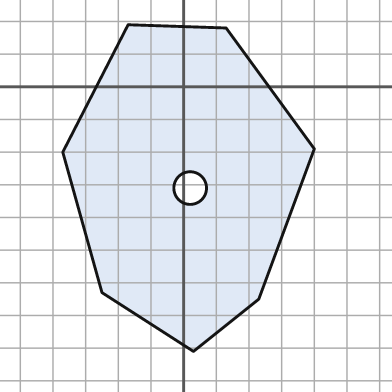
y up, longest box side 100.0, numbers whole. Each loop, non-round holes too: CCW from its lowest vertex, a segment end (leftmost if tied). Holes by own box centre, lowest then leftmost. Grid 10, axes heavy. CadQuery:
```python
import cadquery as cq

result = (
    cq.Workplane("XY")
    .moveTo(3.0, -81.0)
    .lineTo(23.0, -65.0)
    .lineTo(40.0, -19.0)
    .lineTo(13.0, 18.0)
    .lineTo(-17.0, 19.0)
    .lineTo(-37.0, -20.0)
    .lineTo(-25.0, -63.0)
    .close()
    .moveTo(2.0, -31.0)
    .circle(5.0)
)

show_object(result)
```